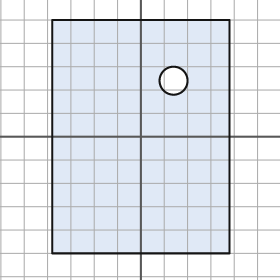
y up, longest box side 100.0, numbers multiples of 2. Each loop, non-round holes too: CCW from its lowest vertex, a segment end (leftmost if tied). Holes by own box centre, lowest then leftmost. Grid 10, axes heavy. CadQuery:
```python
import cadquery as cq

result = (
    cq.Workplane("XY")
    .moveTo(-38.0, -50.0)
    .lineTo(38.0, -50.0)
    .lineTo(38.0, 50.0)
    .lineTo(-38.0, 50.0)
    .close()
    .moveTo(14.0, 24.0)
    .circle(6.0)
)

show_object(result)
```